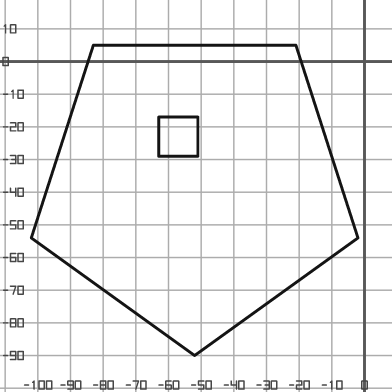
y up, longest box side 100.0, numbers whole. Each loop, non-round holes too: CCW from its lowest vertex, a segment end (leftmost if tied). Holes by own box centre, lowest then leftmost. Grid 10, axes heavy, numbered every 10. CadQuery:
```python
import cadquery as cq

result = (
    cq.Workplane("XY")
    .moveTo(-52.0, -90.0)
    .lineTo(-2.0, -54.0)
    .lineTo(-21.0, 5.0)
    .lineTo(-83.0, 5.0)
    .lineTo(-102.0, -54.0)
    .close()
    .moveTo(-63.0, -29.0)
    .lineTo(-51.0, -29.0)
    .lineTo(-51.0, -17.0)
    .lineTo(-63.0, -17.0)
    .close()
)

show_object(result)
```